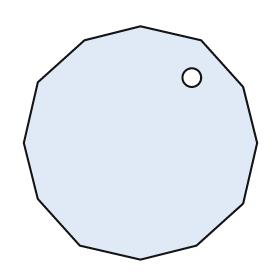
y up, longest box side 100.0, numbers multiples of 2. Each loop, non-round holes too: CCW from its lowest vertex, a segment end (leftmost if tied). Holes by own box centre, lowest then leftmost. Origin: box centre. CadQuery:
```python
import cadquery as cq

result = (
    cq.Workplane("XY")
    .moveTo(0.0, -50.0)
    .lineTo(24.0, -44.0)
    .lineTo(44.0, -26.0)
    .lineTo(50.0, 0.0)
    .lineTo(44.0, 24.0)
    .lineTo(26.0, 44.0)
    .lineTo(0.0, 50.0)
    .lineTo(-24.0, 44.0)
    .lineTo(-44.0, 26.0)
    .lineTo(-50.0, 0.0)
    .lineTo(-44.0, -24.0)
    .lineTo(-26.0, -44.0)
    .close()
    .moveTo(22.0, 28.0)
    .circle(4.0)
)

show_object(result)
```